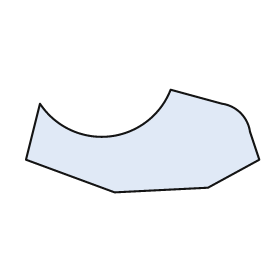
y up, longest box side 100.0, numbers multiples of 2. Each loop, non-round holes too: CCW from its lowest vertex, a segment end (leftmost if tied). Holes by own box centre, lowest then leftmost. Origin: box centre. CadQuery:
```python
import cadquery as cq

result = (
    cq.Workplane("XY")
    .moveTo(-12.0, -22.0)
    .lineTo(28.0, -20.0)
    .lineTo(50.0, -8.0)
    .lineTo(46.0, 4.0)
    .threePointArc((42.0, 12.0), (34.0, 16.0))
    .lineTo(12.0, 22.0)
    .threePointArc((-14.0, 2.0), (-44.0, 16.0))
    .lineTo(-50.0, -8.0)
    .close()
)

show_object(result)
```